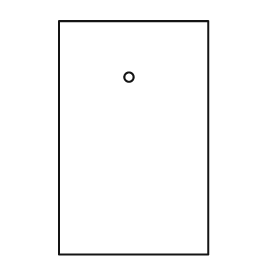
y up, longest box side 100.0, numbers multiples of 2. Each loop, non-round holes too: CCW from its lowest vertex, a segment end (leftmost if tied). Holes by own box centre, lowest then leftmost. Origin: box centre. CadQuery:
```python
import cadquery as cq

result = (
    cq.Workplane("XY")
    .moveTo(-32.0, -50.0)
    .lineTo(32.0, -50.0)
    .lineTo(32.0, 50.0)
    .lineTo(-32.0, 50.0)
    .close()
    .moveTo(-2.0, 26.0)
    .circle(2.0)
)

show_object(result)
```